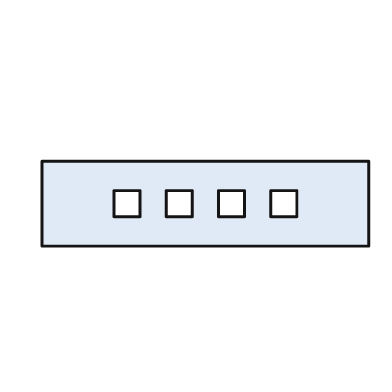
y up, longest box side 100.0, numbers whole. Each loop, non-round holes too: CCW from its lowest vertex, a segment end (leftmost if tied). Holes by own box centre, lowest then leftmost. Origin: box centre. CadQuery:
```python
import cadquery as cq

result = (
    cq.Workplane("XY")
    .moveTo(-50.0, -13.0)
    .lineTo(50.0, -13.0)
    .lineTo(50.0, 13.0)
    .lineTo(-50.0, 13.0)
    .close()
    .moveTo(-28.0, -4.0)
    .lineTo(-20.0, -4.0)
    .lineTo(-20.0, 4.0)
    .lineTo(-28.0, 4.0)
    .close()
    .moveTo(-12.0, -4.0)
    .lineTo(-4.0, -4.0)
    .lineTo(-4.0, 4.0)
    .lineTo(-12.0, 4.0)
    .close()
    .moveTo(4.0, -4.0)
    .lineTo(12.0, -4.0)
    .lineTo(12.0, 4.0)
    .lineTo(4.0, 4.0)
    .close()
    .moveTo(20.0, -4.0)
    .lineTo(28.0, -4.0)
    .lineTo(28.0, 4.0)
    .lineTo(20.0, 4.0)
    .close()
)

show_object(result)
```